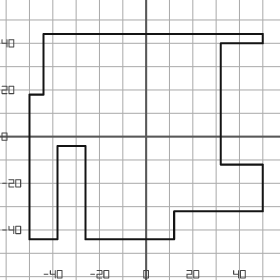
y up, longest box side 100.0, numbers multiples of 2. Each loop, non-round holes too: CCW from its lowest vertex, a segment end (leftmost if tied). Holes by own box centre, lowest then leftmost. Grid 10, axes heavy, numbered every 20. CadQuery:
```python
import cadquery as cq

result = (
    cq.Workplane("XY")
    .moveTo(-50.0, -44.0)
    .lineTo(-38.0, -44.0)
    .lineTo(-38.0, -4.0)
    .lineTo(-26.0, -4.0)
    .lineTo(-26.0, -44.0)
    .lineTo(12.0, -44.0)
    .lineTo(12.0, -32.0)
    .lineTo(50.0, -32.0)
    .lineTo(50.0, -12.0)
    .lineTo(32.0, -12.0)
    .lineTo(32.0, 40.0)
    .lineTo(50.0, 40.0)
    .lineTo(50.0, 44.0)
    .lineTo(-44.0, 44.0)
    .lineTo(-44.0, 18.0)
    .lineTo(-50.0, 18.0)
    .close()
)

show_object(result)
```